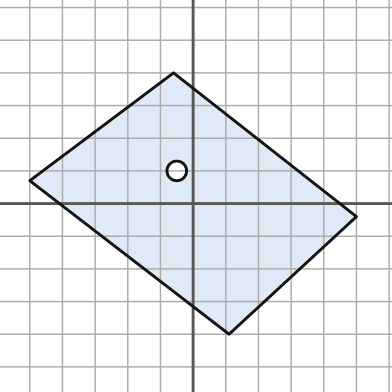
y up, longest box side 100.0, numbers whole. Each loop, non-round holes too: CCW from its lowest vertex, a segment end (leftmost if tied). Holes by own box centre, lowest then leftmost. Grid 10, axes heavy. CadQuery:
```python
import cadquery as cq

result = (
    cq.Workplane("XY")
    .moveTo(11.0, -40.0)
    .lineTo(50.0, -4.0)
    .lineTo(-6.0, 40.0)
    .lineTo(-50.0, 7.0)
    .close()
    .moveTo(-5.0, 10.0)
    .circle(3.0)
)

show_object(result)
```